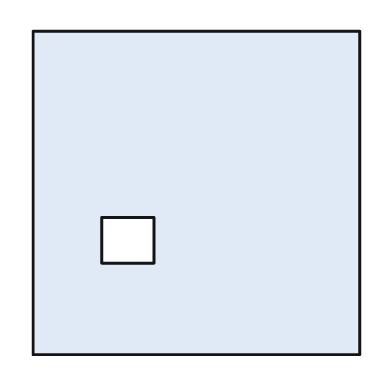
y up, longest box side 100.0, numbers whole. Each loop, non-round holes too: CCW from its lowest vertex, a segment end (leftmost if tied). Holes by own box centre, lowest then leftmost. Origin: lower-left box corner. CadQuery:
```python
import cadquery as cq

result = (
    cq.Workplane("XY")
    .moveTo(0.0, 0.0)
    .lineTo(100.0, 0.0)
    .lineTo(100.0, 99.0)
    .lineTo(0.0, 99.0)
    .close()
    .moveTo(21.0, 28.0)
    .lineTo(37.0, 28.0)
    .lineTo(37.0, 42.0)
    .lineTo(21.0, 42.0)
    .close()
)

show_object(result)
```